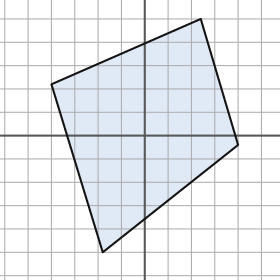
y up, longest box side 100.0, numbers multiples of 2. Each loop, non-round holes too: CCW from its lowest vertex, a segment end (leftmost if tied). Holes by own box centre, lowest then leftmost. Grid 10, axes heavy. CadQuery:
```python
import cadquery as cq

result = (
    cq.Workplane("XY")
    .moveTo(-18.0, -50.0)
    .lineTo(40.0, -4.0)
    .lineTo(24.0, 50.0)
    .lineTo(-40.0, 22.0)
    .close()
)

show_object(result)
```